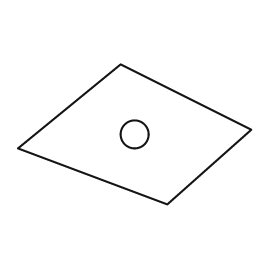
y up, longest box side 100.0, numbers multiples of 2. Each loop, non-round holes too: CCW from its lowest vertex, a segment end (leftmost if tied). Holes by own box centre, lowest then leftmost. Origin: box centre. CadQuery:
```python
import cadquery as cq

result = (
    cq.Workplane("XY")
    .moveTo(14.0, -30.0)
    .lineTo(50.0, 2.0)
    .lineTo(-6.0, 30.0)
    .lineTo(-50.0, -6.0)
    .close()
    .moveTo(0.0, 0.0)
    .circle(6.0)
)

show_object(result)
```